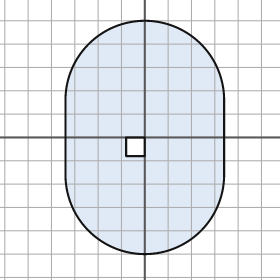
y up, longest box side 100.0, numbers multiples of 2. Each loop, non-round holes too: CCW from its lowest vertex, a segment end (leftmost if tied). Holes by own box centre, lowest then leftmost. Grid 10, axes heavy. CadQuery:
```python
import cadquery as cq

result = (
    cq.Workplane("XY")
    .moveTo(-34.0, -16.0)
    .threePointArc((0.0, -50.0), (34.0, -16.0))
    .lineTo(34.0, 16.0)
    .threePointArc((0.0, 50.0), (-34.0, 16.0))
    .close()
    .moveTo(-8.0, -8.0)
    .lineTo(0.0, -8.0)
    .lineTo(0.0, 0.0)
    .lineTo(-8.0, 0.0)
    .close()
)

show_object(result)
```